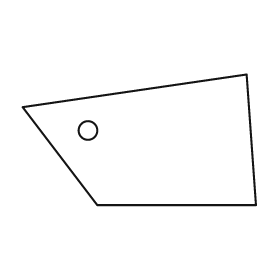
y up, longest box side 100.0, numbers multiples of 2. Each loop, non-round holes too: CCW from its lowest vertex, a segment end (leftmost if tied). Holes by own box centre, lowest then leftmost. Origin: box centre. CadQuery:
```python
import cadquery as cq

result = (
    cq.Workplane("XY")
    .moveTo(-18.0, -28.0)
    .lineTo(50.0, -28.0)
    .lineTo(46.0, 28.0)
    .lineTo(-50.0, 14.0)
    .close()
    .moveTo(-22.0, 4.0)
    .circle(4.0)
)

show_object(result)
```